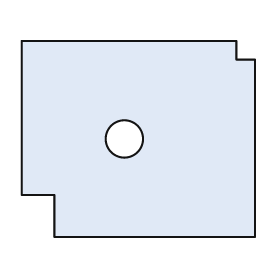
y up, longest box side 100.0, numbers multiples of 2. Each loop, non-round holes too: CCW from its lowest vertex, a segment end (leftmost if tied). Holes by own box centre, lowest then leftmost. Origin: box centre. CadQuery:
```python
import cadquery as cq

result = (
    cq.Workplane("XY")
    .moveTo(-36.0, -42.0)
    .lineTo(50.0, -42.0)
    .lineTo(50.0, 34.0)
    .lineTo(42.0, 34.0)
    .lineTo(42.0, 42.0)
    .lineTo(-50.0, 42.0)
    .lineTo(-50.0, -24.0)
    .lineTo(-36.0, -24.0)
    .close()
    .moveTo(-6.0, 0.0)
    .circle(8.0)
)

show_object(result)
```